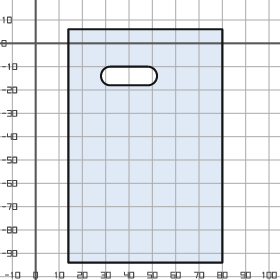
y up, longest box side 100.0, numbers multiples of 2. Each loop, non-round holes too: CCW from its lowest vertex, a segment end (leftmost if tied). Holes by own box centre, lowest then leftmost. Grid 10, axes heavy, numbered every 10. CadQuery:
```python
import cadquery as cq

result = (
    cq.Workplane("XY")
    .moveTo(14.0, -94.0)
    .lineTo(80.0, -94.0)
    .lineTo(80.0, 6.0)
    .lineTo(14.0, 6.0)
    .close()
    .moveTo(32.0, -18.0)
    .lineTo(48.0, -18.0)
    .threePointArc((52.0, -14.0), (48.0, -10.0))
    .lineTo(32.0, -10.0)
    .threePointArc((28.0, -14.0), (32.0, -18.0))
    .close()
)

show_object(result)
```